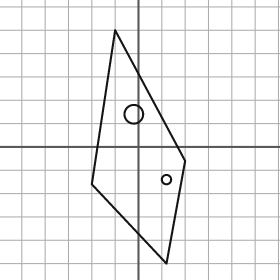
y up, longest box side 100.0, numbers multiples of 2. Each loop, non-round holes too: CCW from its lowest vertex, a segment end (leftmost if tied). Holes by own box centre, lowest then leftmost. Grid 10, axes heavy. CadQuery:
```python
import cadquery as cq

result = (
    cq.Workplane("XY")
    .moveTo(12.0, -50.0)
    .lineTo(20.0, -6.0)
    .lineTo(-10.0, 50.0)
    .lineTo(-20.0, -16.0)
    .close()
    .moveTo(12.0, -14.0)
    .circle(2.0)
    .moveTo(-2.0, 14.0)
    .circle(4.0)
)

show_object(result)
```